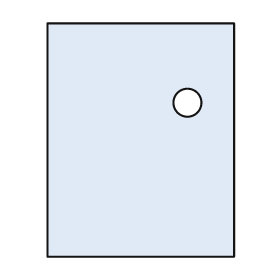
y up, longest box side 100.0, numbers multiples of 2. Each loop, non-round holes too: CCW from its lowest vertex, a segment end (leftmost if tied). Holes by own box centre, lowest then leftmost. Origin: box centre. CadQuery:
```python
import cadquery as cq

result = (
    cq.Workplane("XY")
    .moveTo(-40.0, -50.0)
    .lineTo(40.0, -50.0)
    .lineTo(40.0, 50.0)
    .lineTo(-40.0, 50.0)
    .close()
    .moveTo(20.0, 16.0)
    .circle(6.0)
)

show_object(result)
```